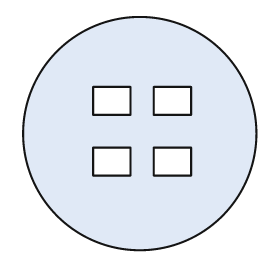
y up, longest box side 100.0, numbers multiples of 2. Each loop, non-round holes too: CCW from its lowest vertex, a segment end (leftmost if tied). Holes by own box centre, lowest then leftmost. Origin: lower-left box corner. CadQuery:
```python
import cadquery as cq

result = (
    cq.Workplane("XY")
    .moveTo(50.0, 50.0)
    .circle(50.0)
    .moveTo(30.0, 32.0)
    .lineTo(46.0, 32.0)
    .lineTo(46.0, 44.0)
    .lineTo(30.0, 44.0)
    .close()
    .moveTo(56.0, 32.0)
    .lineTo(72.0, 32.0)
    .lineTo(72.0, 44.0)
    .lineTo(56.0, 44.0)
    .close()
    .moveTo(30.0, 58.0)
    .lineTo(46.0, 58.0)
    .lineTo(46.0, 70.0)
    .lineTo(30.0, 70.0)
    .close()
    .moveTo(56.0, 58.0)
    .lineTo(72.0, 58.0)
    .lineTo(72.0, 70.0)
    .lineTo(56.0, 70.0)
    .close()
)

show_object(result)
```